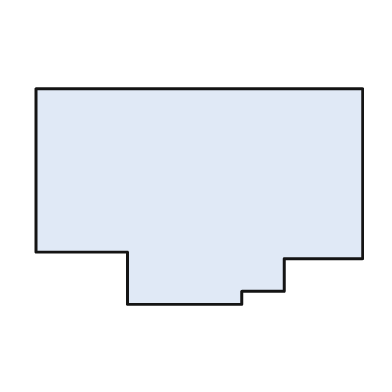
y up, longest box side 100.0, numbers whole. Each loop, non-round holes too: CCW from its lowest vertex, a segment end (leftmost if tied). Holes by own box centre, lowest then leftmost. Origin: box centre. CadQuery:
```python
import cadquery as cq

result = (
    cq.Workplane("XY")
    .moveTo(-22.0, -33.0)
    .lineTo(13.0, -33.0)
    .lineTo(13.0, -29.0)
    .lineTo(26.0, -29.0)
    .lineTo(26.0, -19.0)
    .lineTo(50.0, -19.0)
    .lineTo(50.0, 33.0)
    .lineTo(-50.0, 33.0)
    .lineTo(-50.0, -17.0)
    .lineTo(-22.0, -17.0)
    .close()
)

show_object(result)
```